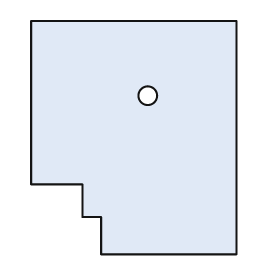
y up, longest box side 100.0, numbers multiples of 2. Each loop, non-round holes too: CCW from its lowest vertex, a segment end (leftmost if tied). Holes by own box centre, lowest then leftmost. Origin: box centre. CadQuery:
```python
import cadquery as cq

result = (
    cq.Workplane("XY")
    .moveTo(-14.0, -50.0)
    .lineTo(44.0, -50.0)
    .lineTo(44.0, 50.0)
    .lineTo(-44.0, 50.0)
    .lineTo(-44.0, -20.0)
    .lineTo(-22.0, -20.0)
    .lineTo(-22.0, -34.0)
    .lineTo(-14.0, -34.0)
    .close()
    .moveTo(6.0, 18.0)
    .circle(4.0)
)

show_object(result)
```